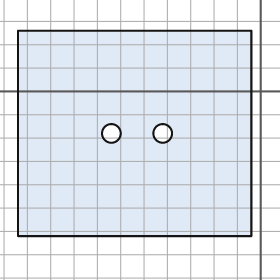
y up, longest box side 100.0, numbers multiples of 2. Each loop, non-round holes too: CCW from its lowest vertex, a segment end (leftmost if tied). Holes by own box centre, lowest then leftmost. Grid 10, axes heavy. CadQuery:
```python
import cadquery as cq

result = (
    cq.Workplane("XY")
    .moveTo(-104.0, -62.0)
    .lineTo(-4.0, -62.0)
    .lineTo(-4.0, 26.0)
    .lineTo(-104.0, 26.0)
    .close()
    .moveTo(-64.0, -18.0)
    .circle(4.0)
    .moveTo(-42.0, -18.0)
    .circle(4.0)
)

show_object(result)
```